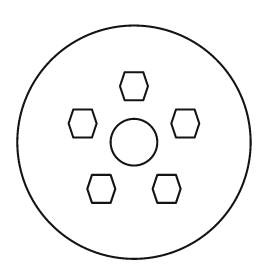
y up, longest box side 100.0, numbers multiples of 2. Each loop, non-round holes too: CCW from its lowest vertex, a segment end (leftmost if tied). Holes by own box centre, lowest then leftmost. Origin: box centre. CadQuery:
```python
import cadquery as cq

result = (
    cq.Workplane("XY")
    .moveTo(0.0, 0.0)
    .circle(50.0)
    .moveTo(-18.0, -26.0)
    .lineTo(-10.0, -26.0)
    .lineTo(-8.0, -20.0)
    .lineTo(-10.0, -14.0)
    .lineTo(-18.0, -14.0)
    .lineTo(-20.0, -20.0)
    .close()
    .moveTo(10.0, -26.0)
    .lineTo(18.0, -26.0)
    .lineTo(20.0, -20.0)
    .lineTo(18.0, -14.0)
    .lineTo(10.0, -14.0)
    .lineTo(8.0, -20.0)
    .close()
    .moveTo(0.0, 0.0)
    .circle(10.0)
    .moveTo(-26.0, 2.0)
    .lineTo(-18.0, 2.0)
    .lineTo(-16.0, 8.0)
    .lineTo(-18.0, 14.0)
    .lineTo(-26.0, 14.0)
    .lineTo(-28.0, 8.0)
    .close()
    .moveTo(18.0, 2.0)
    .lineTo(26.0, 2.0)
    .lineTo(28.0, 8.0)
    .lineTo(26.0, 14.0)
    .lineTo(18.0, 14.0)
    .lineTo(16.0, 8.0)
    .close()
    .moveTo(-4.0, 18.0)
    .lineTo(4.0, 18.0)
    .lineTo(6.0, 24.0)
    .lineTo(4.0, 30.0)
    .lineTo(-4.0, 30.0)
    .lineTo(-6.0, 24.0)
    .close()
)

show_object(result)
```